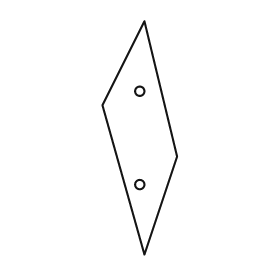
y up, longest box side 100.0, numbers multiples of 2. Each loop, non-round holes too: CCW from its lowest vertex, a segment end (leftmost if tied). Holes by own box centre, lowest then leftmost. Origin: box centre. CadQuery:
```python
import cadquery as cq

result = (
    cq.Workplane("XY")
    .moveTo(2.0, -50.0)
    .lineTo(16.0, -8.0)
    .lineTo(2.0, 50.0)
    .lineTo(-16.0, 14.0)
    .close()
    .moveTo(0.0, -20.0)
    .circle(2.0)
    .moveTo(0.0, 20.0)
    .circle(2.0)
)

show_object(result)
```